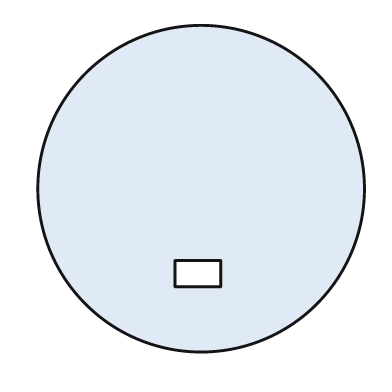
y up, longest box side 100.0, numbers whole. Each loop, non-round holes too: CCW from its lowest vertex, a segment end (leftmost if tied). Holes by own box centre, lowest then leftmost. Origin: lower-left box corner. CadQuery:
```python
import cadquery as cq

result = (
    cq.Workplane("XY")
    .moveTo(50.0, 50.0)
    .circle(50.0)
    .moveTo(42.0, 20.0)
    .lineTo(56.0, 20.0)
    .lineTo(56.0, 28.0)
    .lineTo(42.0, 28.0)
    .close()
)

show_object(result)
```